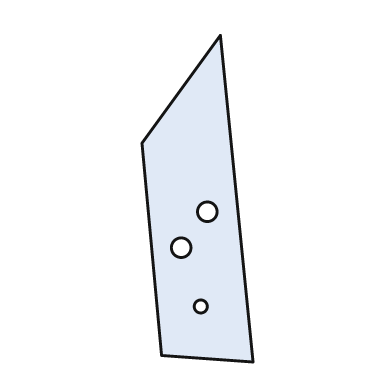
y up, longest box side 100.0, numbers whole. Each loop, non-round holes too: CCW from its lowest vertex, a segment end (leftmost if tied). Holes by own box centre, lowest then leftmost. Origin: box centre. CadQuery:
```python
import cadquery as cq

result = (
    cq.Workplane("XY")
    .moveTo(17.0, -50.0)
    .lineTo(7.0, 50.0)
    .lineTo(-17.0, 17.0)
    .lineTo(-11.0, -48.0)
    .close()
    .moveTo(1.0, -33.0)
    .circle(2.0)
    .moveTo(-5.0, -15.0)
    .circle(3.0)
    .moveTo(3.0, -4.0)
    .circle(3.0)
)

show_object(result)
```